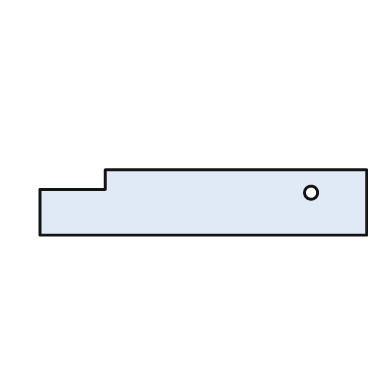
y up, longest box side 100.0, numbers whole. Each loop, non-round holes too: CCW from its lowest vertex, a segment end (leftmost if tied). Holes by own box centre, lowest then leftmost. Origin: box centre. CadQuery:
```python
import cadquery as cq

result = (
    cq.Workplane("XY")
    .moveTo(-50.0, -10.0)
    .lineTo(50.0, -10.0)
    .lineTo(50.0, 10.0)
    .lineTo(-30.0, 10.0)
    .lineTo(-30.0, 4.0)
    .lineTo(-50.0, 4.0)
    .close()
    .moveTo(33.0, 3.0)
    .circle(2.0)
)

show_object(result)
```